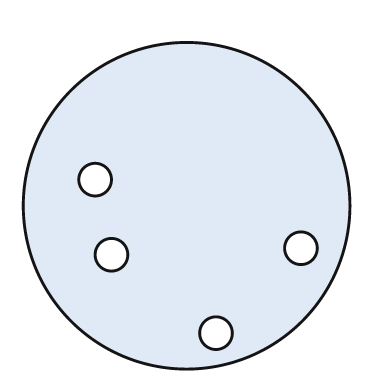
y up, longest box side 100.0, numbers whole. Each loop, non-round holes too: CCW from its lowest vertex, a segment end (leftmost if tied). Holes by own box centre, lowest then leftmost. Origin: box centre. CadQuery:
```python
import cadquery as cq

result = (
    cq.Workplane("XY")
    .moveTo(0.0, 0.0)
    .circle(50.0)
    .moveTo(9.0, -39.0)
    .circle(5.0)
    .moveTo(-23.0, -15.0)
    .circle(5.0)
    .moveTo(35.0, -13.0)
    .circle(5.0)
    .moveTo(-28.0, 8.0)
    .circle(5.0)
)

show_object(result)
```